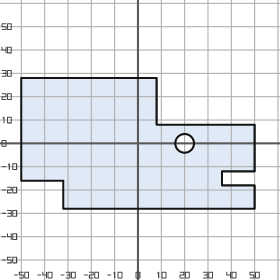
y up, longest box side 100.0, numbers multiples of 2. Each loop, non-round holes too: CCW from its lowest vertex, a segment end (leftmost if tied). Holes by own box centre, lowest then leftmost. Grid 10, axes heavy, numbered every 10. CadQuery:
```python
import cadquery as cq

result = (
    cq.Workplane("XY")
    .moveTo(-32.0, -28.0)
    .lineTo(50.0, -28.0)
    .lineTo(50.0, -18.0)
    .lineTo(36.0, -18.0)
    .lineTo(36.0, -12.0)
    .lineTo(50.0, -12.0)
    .lineTo(50.0, 8.0)
    .lineTo(8.0, 8.0)
    .lineTo(8.0, 28.0)
    .lineTo(-50.0, 28.0)
    .lineTo(-50.0, -16.0)
    .lineTo(-32.0, -16.0)
    .close()
    .moveTo(20.0, 0.0)
    .circle(4.0)
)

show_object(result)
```